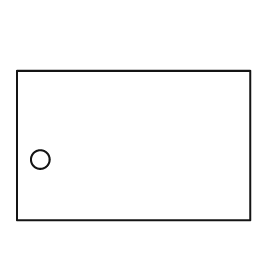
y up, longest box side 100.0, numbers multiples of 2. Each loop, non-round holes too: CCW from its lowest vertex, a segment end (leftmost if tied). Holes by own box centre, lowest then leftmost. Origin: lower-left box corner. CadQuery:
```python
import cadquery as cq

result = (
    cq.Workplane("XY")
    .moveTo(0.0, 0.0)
    .lineTo(100.0, 0.0)
    .lineTo(100.0, 64.0)
    .lineTo(0.0, 64.0)
    .close()
    .moveTo(10.0, 26.0)
    .circle(4.0)
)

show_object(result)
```